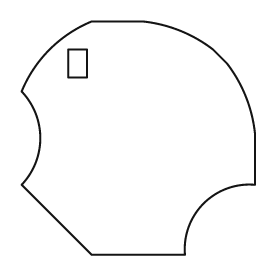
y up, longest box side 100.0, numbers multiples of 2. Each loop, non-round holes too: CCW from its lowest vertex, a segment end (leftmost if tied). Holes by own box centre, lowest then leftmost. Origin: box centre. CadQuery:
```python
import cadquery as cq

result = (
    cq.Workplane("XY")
    .moveTo(-20.0, -50.0)
    .lineTo(20.0, -50.0)
    .threePointArc((28.0, -28.0), (50.0, -20.0))
    .lineTo(50.0, 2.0)
    .threePointArc((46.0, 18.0), (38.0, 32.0))
    .lineTo(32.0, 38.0)
    .threePointArc((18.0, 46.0), (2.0, 50.0))
    .lineTo(-20.0, 50.0)
    .threePointArc((-38.0, 38.0), (-50.0, 20.0))
    .threePointArc((-42.0, 0.0), (-50.0, -20.0))
    .close()
    .moveTo(-30.0, 26.0)
    .lineTo(-22.0, 26.0)
    .lineTo(-22.0, 38.0)
    .lineTo(-30.0, 38.0)
    .close()
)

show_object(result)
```